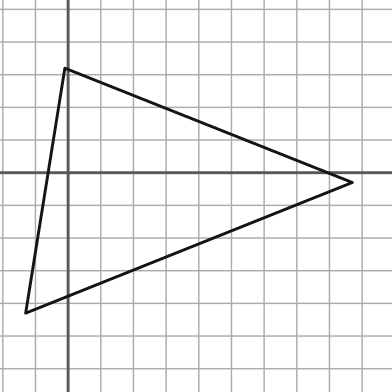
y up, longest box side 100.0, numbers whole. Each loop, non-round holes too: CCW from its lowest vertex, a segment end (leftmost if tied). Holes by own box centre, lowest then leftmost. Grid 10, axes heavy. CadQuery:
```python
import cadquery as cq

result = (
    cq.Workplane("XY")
    .moveTo(-13.0, -43.0)
    .lineTo(87.0, -3.0)
    .lineTo(-1.0, 32.0)
    .close()
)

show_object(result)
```